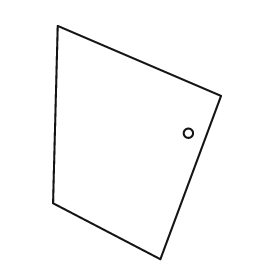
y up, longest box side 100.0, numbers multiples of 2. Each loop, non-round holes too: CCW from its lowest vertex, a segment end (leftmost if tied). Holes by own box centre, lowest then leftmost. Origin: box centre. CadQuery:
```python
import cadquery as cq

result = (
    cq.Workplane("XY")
    .moveTo(10.0, -50.0)
    .lineTo(36.0, 20.0)
    .lineTo(-34.0, 50.0)
    .lineTo(-36.0, -26.0)
    .close()
    .moveTo(22.0, 4.0)
    .circle(2.0)
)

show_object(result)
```